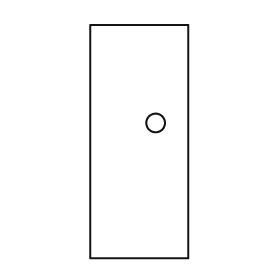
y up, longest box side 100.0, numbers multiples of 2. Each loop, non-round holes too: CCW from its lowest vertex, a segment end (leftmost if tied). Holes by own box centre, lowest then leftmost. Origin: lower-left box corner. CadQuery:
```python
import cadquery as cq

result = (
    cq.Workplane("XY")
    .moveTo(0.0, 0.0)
    .lineTo(42.0, 0.0)
    .lineTo(42.0, 100.0)
    .lineTo(0.0, 100.0)
    .close()
    .moveTo(28.0, 58.0)
    .circle(4.0)
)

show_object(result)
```